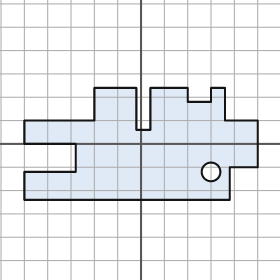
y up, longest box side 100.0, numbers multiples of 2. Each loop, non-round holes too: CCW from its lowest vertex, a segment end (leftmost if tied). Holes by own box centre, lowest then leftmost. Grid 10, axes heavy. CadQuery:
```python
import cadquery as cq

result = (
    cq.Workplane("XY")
    .moveTo(-50.0, -24.0)
    .lineTo(38.0, -24.0)
    .lineTo(38.0, -10.0)
    .lineTo(50.0, -10.0)
    .lineTo(50.0, 10.0)
    .lineTo(36.0, 10.0)
    .lineTo(36.0, 24.0)
    .lineTo(30.0, 24.0)
    .lineTo(30.0, 18.0)
    .lineTo(20.0, 18.0)
    .lineTo(20.0, 24.0)
    .lineTo(4.0, 24.0)
    .lineTo(4.0, 6.0)
    .lineTo(-2.0, 6.0)
    .lineTo(-2.0, 24.0)
    .lineTo(-20.0, 24.0)
    .lineTo(-20.0, 10.0)
    .lineTo(-50.0, 10.0)
    .lineTo(-50.0, 0.0)
    .lineTo(-28.0, 0.0)
    .lineTo(-28.0, -12.0)
    .lineTo(-50.0, -12.0)
    .close()
    .moveTo(30.0, -12.0)
    .circle(4.0)
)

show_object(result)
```